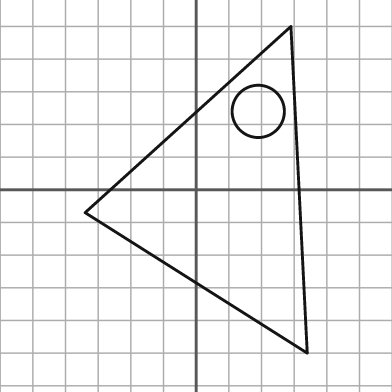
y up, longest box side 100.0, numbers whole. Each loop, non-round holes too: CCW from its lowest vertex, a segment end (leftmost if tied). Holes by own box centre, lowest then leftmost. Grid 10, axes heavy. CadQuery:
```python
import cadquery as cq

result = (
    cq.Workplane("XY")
    .moveTo(34.0, -50.0)
    .lineTo(29.0, 50.0)
    .lineTo(-34.0, -7.0)
    .close()
    .moveTo(19.0, 24.0)
    .circle(8.0)
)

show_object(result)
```